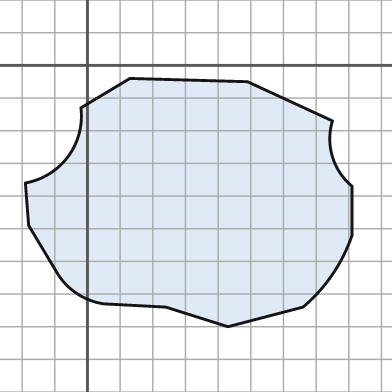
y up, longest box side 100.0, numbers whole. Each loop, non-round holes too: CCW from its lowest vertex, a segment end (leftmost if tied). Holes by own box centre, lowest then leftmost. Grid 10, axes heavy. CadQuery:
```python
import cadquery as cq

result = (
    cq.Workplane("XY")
    .moveTo(43.0, -80.0)
    .lineTo(66.0, -74.0)
    .threePointArc((75.0, -64.0), (81.0, -52.0))
    .lineTo(81.0, -37.0)
    .threePointArc((75.0, -28.0), (75.0, -17.0))
    .lineTo(49.0, -5.0)
    .lineTo(13.0, -4.0)
    .lineTo(-2.0, -13.0)
    .threePointArc((-6.0, -28.0), (-19.0, -36.0))
    .lineTo(-18.0, -49.0)
    .lineTo(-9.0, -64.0)
    .threePointArc((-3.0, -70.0), (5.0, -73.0))
    .lineTo(24.0, -74.0)
    .close()
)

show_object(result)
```